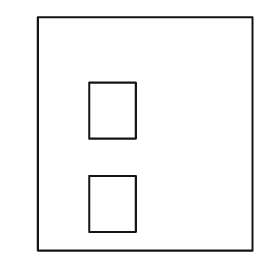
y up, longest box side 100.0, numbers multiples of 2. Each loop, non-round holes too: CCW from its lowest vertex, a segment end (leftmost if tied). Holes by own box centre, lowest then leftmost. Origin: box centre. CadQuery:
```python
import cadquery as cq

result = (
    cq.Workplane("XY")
    .moveTo(-46.0, -50.0)
    .lineTo(46.0, -50.0)
    .lineTo(46.0, 50.0)
    .lineTo(-46.0, 50.0)
    .close()
    .moveTo(-24.0, -42.0)
    .lineTo(-4.0, -42.0)
    .lineTo(-4.0, -18.0)
    .lineTo(-24.0, -18.0)
    .close()
    .moveTo(-24.0, -2.0)
    .lineTo(-4.0, -2.0)
    .lineTo(-4.0, 22.0)
    .lineTo(-24.0, 22.0)
    .close()
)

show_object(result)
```